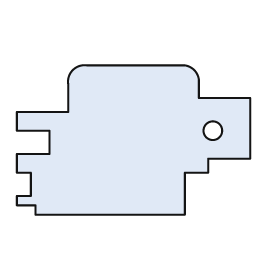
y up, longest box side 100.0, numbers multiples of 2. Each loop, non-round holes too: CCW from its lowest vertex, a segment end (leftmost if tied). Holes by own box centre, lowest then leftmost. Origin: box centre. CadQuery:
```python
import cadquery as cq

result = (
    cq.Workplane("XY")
    .moveTo(-42.0, -32.0)
    .lineTo(22.0, -32.0)
    .lineTo(22.0, -14.0)
    .lineTo(32.0, -14.0)
    .lineTo(32.0, -8.0)
    .lineTo(50.0, -8.0)
    .lineTo(50.0, 18.0)
    .lineTo(28.0, 18.0)
    .lineTo(28.0, 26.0)
    .threePointArc((26.0, 30.0), (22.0, 32.0))
    .lineTo(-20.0, 32.0)
    .threePointArc((-26.0, 30.0), (-28.0, 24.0))
    .lineTo(-28.0, 12.0)
    .lineTo(-50.0, 12.0)
    .lineTo(-50.0, 4.0)
    .lineTo(-36.0, 4.0)
    .lineTo(-36.0, -6.0)
    .lineTo(-50.0, -6.0)
    .lineTo(-50.0, -14.0)
    .lineTo(-44.0, -14.0)
    .lineTo(-44.0, -24.0)
    .lineTo(-50.0, -24.0)
    .lineTo(-50.0, -28.0)
    .lineTo(-42.0, -28.0)
    .close()
    .moveTo(34.0, 4.0)
    .circle(4.0)
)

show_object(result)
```